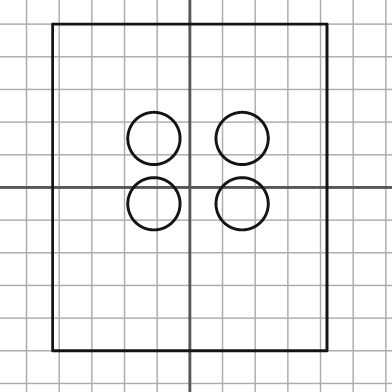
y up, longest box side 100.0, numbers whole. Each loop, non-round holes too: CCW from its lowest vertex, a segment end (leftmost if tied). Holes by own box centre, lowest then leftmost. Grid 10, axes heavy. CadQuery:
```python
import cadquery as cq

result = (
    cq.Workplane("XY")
    .moveTo(-42.0, -50.0)
    .lineTo(42.0, -50.0)
    .lineTo(42.0, 50.0)
    .lineTo(-42.0, 50.0)
    .close()
    .moveTo(-11.0, -5.0)
    .circle(8.0)
    .moveTo(16.0, -5.0)
    .circle(8.0)
    .moveTo(-11.0, 15.0)
    .circle(8.0)
    .moveTo(16.0, 15.0)
    .circle(8.0)
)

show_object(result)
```